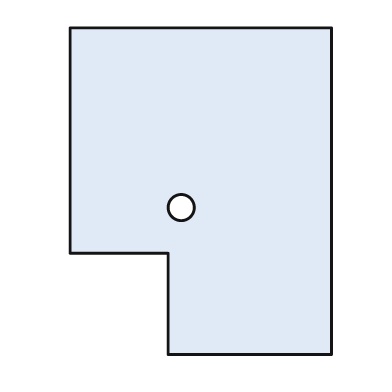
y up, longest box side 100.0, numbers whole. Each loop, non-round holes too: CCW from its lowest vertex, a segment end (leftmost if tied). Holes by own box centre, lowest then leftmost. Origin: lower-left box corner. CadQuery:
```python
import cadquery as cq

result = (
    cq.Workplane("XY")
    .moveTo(30.0, 0.0)
    .lineTo(80.0, 0.0)
    .lineTo(80.0, 100.0)
    .lineTo(0.0, 100.0)
    .lineTo(0.0, 31.0)
    .lineTo(30.0, 31.0)
    .close()
    .moveTo(34.0, 45.0)
    .circle(4.0)
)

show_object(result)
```